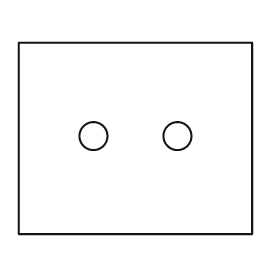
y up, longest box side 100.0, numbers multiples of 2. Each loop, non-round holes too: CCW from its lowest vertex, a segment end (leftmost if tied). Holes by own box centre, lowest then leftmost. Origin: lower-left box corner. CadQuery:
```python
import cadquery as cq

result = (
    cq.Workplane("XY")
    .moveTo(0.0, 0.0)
    .lineTo(100.0, 0.0)
    .lineTo(100.0, 82.0)
    .lineTo(0.0, 82.0)
    .close()
    .moveTo(32.0, 42.0)
    .circle(6.0)
    .moveTo(68.0, 42.0)
    .circle(6.0)
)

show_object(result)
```